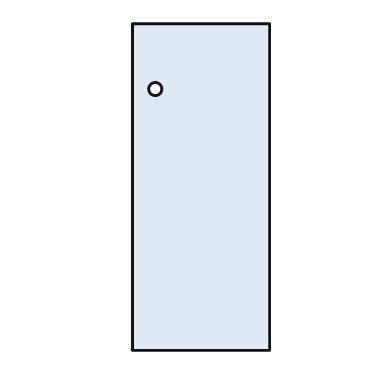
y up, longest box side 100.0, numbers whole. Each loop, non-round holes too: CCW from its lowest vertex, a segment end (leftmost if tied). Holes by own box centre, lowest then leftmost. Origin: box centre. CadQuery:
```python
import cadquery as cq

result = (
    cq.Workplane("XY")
    .moveTo(-21.0, -50.0)
    .lineTo(21.0, -50.0)
    .lineTo(21.0, 50.0)
    .lineTo(-21.0, 50.0)
    .close()
    .moveTo(-14.0, 30.0)
    .circle(2.0)
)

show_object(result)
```